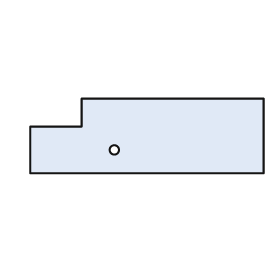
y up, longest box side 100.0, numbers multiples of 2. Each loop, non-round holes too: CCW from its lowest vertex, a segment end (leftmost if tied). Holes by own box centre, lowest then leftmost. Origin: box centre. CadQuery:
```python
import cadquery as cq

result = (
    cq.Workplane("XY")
    .moveTo(-50.0, -16.0)
    .lineTo(50.0, -16.0)
    .lineTo(50.0, 16.0)
    .lineTo(-28.0, 16.0)
    .lineTo(-28.0, 4.0)
    .lineTo(-50.0, 4.0)
    .close()
    .moveTo(-14.0, -6.0)
    .circle(2.0)
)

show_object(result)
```